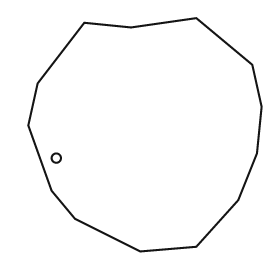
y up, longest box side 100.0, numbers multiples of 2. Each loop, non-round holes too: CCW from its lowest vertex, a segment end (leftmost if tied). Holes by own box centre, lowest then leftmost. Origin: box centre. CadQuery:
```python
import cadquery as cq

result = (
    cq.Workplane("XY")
    .moveTo(-2.0, -50.0)
    .lineTo(22.0, -48.0)
    .lineTo(40.0, -28.0)
    .lineTo(48.0, -8.0)
    .lineTo(50.0, 12.0)
    .lineTo(46.0, 30.0)
    .lineTo(22.0, 50.0)
    .lineTo(-6.0, 46.0)
    .lineTo(-26.0, 48.0)
    .lineTo(-46.0, 22.0)
    .lineTo(-50.0, 4.0)
    .lineTo(-40.0, -24.0)
    .lineTo(-30.0, -36.0)
    .close()
    .moveTo(-38.0, -10.0)
    .circle(2.0)
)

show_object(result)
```